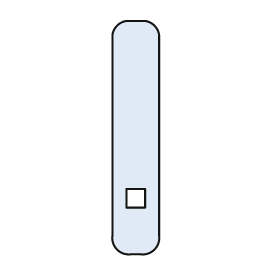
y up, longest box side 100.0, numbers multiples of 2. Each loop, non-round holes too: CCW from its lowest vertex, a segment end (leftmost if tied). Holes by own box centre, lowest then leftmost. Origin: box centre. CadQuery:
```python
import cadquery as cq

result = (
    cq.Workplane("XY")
    .moveTo(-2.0, -50.0)
    .lineTo(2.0, -50.0)
    .threePointArc((8.0, -48.0), (10.0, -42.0))
    .lineTo(10.0, 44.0)
    .threePointArc((8.0, 48.0), (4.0, 50.0))
    .lineTo(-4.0, 50.0)
    .threePointArc((-8.0, 48.0), (-10.0, 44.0))
    .lineTo(-10.0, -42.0)
    .threePointArc((-8.0, -48.0), (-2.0, -50.0))
    .close()
    .moveTo(-4.0, -30.0)
    .lineTo(4.0, -30.0)
    .lineTo(4.0, -22.0)
    .lineTo(-4.0, -22.0)
    .close()
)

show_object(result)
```